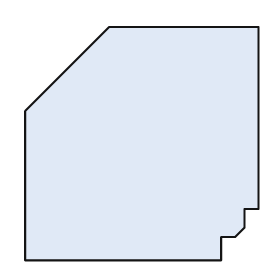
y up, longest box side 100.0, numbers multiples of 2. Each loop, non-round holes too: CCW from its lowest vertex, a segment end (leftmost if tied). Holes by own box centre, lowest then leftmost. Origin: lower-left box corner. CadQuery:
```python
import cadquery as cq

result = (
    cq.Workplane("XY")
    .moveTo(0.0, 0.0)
    .lineTo(84.0, 0.0)
    .lineTo(84.0, 10.0)
    .lineTo(90.0, 10.0)
    .lineTo(94.0, 14.0)
    .lineTo(94.0, 22.0)
    .lineTo(100.0, 22.0)
    .lineTo(100.0, 100.0)
    .lineTo(36.0, 100.0)
    .lineTo(0.0, 64.0)
    .close()
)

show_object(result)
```